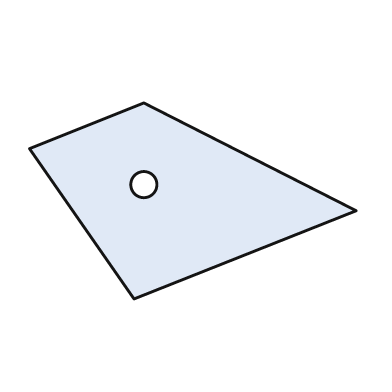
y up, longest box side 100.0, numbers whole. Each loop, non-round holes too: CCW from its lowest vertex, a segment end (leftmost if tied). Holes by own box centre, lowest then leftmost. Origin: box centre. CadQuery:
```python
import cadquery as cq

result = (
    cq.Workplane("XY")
    .moveTo(-18.0, -30.0)
    .lineTo(50.0, -3.0)
    .lineTo(-15.0, 30.0)
    .lineTo(-50.0, 16.0)
    .close()
    .moveTo(-15.0, 5.0)
    .circle(4.0)
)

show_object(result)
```